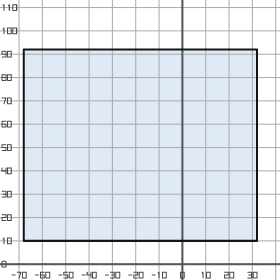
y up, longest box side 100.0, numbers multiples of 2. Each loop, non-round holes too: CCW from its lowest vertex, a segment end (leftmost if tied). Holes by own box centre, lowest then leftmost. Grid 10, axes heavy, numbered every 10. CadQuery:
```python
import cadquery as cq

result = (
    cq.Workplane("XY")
    .moveTo(-68.0, 10.0)
    .lineTo(32.0, 10.0)
    .lineTo(32.0, 92.0)
    .lineTo(-68.0, 92.0)
    .close()
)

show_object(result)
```